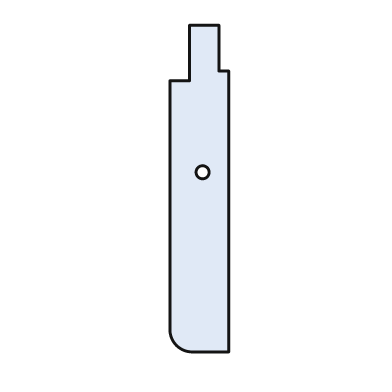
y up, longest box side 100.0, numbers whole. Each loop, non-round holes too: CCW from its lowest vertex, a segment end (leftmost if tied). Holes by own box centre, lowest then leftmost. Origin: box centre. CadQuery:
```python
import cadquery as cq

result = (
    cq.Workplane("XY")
    .moveTo(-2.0, -50.0)
    .lineTo(9.0, -50.0)
    .lineTo(9.0, 36.0)
    .lineTo(6.0, 36.0)
    .lineTo(6.0, 50.0)
    .lineTo(-3.0, 50.0)
    .lineTo(-3.0, 33.0)
    .lineTo(-9.0, 33.0)
    .lineTo(-9.0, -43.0)
    .threePointArc((-7.0, -48.0), (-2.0, -50.0))
    .close()
    .moveTo(1.0, 5.0)
    .circle(2.0)
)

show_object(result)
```